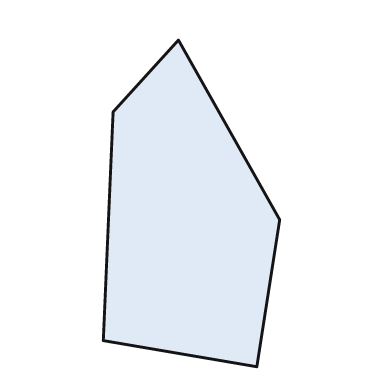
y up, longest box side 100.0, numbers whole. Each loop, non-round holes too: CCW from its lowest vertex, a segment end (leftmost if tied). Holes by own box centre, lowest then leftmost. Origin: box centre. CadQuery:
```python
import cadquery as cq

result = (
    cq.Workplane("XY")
    .moveTo(20.0, -50.0)
    .lineTo(27.0, -5.0)
    .lineTo(-4.0, 50.0)
    .lineTo(-24.0, 28.0)
    .lineTo(-27.0, -42.0)
    .close()
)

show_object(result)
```